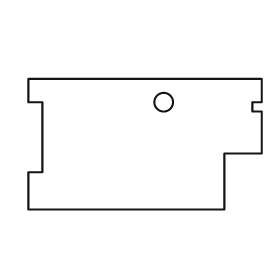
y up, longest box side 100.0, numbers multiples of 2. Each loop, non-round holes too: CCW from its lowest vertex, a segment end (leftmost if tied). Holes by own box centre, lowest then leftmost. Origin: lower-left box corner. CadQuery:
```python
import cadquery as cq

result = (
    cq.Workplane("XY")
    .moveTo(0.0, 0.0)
    .lineTo(84.0, 0.0)
    .lineTo(84.0, 24.0)
    .lineTo(100.0, 24.0)
    .lineTo(100.0, 42.0)
    .lineTo(96.0, 42.0)
    .lineTo(96.0, 46.0)
    .lineTo(100.0, 46.0)
    .lineTo(100.0, 56.0)
    .lineTo(0.0, 56.0)
    .lineTo(0.0, 46.0)
    .lineTo(6.0, 46.0)
    .lineTo(6.0, 16.0)
    .lineTo(0.0, 16.0)
    .close()
    .moveTo(58.0, 46.0)
    .circle(4.0)
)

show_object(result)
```